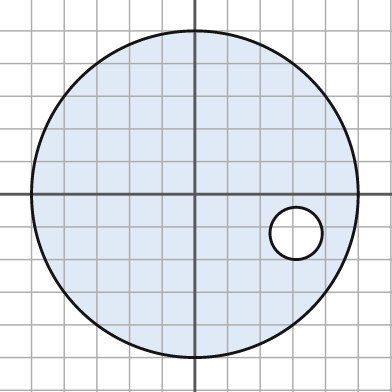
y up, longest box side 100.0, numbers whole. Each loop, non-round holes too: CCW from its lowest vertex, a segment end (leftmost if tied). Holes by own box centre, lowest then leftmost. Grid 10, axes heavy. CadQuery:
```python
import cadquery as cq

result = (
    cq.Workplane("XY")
    .moveTo(0.0, 0.0)
    .circle(50.0)
    .moveTo(31.0, -12.0)
    .circle(8.0)
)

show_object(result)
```